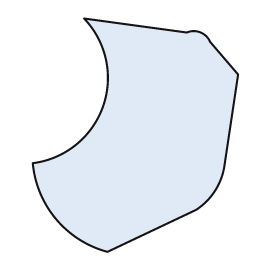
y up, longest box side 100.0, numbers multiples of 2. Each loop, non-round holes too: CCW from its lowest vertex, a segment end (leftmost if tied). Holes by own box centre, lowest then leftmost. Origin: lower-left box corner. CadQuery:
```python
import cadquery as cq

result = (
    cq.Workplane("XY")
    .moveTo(32.0, 0.0)
    .lineTo(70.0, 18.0)
    .threePointArc((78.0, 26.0), (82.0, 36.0))
    .lineTo(88.0, 76.0)
    .lineTo(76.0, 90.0)
    .threePointArc((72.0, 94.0), (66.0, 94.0))
    .lineTo(22.0, 100.0)
    .threePointArc((30.0, 62.0), (0.0, 38.0))
    .threePointArc((10.0, 14.0), (32.0, 0.0))
    .close()
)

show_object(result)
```